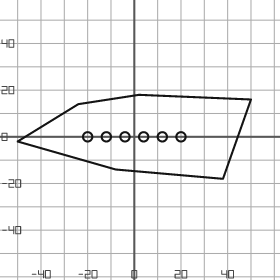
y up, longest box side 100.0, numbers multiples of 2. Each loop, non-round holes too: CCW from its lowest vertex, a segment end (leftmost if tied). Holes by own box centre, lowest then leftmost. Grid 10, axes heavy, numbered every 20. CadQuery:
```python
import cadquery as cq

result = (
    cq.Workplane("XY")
    .moveTo(38.0, -18.0)
    .lineTo(50.0, 16.0)
    .lineTo(2.0, 18.0)
    .lineTo(-24.0, 14.0)
    .lineTo(-50.0, -2.0)
    .lineTo(-8.0, -14.0)
    .close()
    .moveTo(-20.0, 0.0)
    .circle(2.0)
    .moveTo(-12.0, 0.0)
    .circle(2.0)
    .moveTo(-4.0, 0.0)
    .circle(2.0)
    .moveTo(4.0, 0.0)
    .circle(2.0)
    .moveTo(12.0, 0.0)
    .circle(2.0)
    .moveTo(20.0, 0.0)
    .circle(2.0)
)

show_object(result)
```